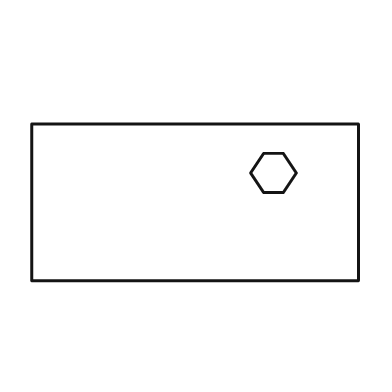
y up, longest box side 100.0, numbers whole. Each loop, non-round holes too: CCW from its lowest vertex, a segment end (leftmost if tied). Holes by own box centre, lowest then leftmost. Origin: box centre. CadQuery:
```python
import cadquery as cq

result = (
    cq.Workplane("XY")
    .moveTo(-50.0, -24.0)
    .lineTo(50.0, -24.0)
    .lineTo(50.0, 24.0)
    .lineTo(-50.0, 24.0)
    .close()
    .moveTo(21.0, 3.0)
    .lineTo(27.0, 3.0)
    .lineTo(31.0, 9.0)
    .lineTo(27.0, 15.0)
    .lineTo(21.0, 15.0)
    .lineTo(17.0, 9.0)
    .close()
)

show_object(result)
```